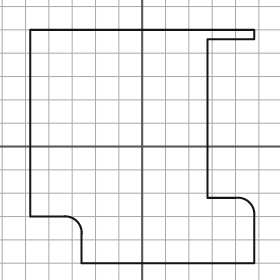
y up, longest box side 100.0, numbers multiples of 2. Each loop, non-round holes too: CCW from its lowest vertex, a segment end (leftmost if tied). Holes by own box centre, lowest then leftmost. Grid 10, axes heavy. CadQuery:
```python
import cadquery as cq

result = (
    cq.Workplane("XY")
    .moveTo(-26.0, -50.0)
    .lineTo(48.0, -50.0)
    .lineTo(48.0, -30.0)
    .threePointArc((46.0, -24.0), (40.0, -22.0))
    .lineTo(28.0, -22.0)
    .lineTo(28.0, 46.0)
    .lineTo(48.0, 46.0)
    .lineTo(48.0, 50.0)
    .lineTo(-48.0, 50.0)
    .lineTo(-48.0, -30.0)
    .lineTo(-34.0, -30.0)
    .threePointArc((-28.0, -32.0), (-26.0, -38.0))
    .close()
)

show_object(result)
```